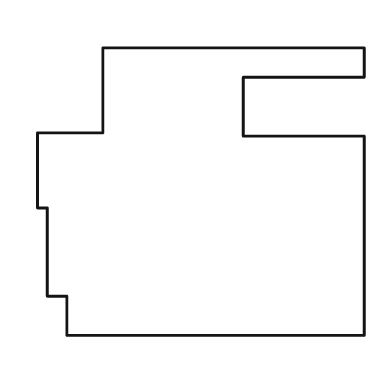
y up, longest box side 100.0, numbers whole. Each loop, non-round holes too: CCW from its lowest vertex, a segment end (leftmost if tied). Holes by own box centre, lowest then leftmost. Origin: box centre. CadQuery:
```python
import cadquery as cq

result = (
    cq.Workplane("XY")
    .moveTo(-41.0, -44.0)
    .lineTo(50.0, -44.0)
    .lineTo(50.0, 17.0)
    .lineTo(13.0, 17.0)
    .lineTo(13.0, 35.0)
    .lineTo(50.0, 35.0)
    .lineTo(50.0, 44.0)
    .lineTo(-30.0, 44.0)
    .lineTo(-30.0, 18.0)
    .lineTo(-50.0, 18.0)
    .lineTo(-50.0, -5.0)
    .lineTo(-47.0, -5.0)
    .lineTo(-47.0, -32.0)
    .lineTo(-41.0, -32.0)
    .close()
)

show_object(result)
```